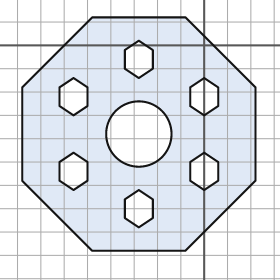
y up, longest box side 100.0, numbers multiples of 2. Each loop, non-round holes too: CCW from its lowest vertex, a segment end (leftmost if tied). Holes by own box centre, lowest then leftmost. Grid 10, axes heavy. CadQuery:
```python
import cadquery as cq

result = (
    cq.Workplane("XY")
    .moveTo(-48.0, -88.0)
    .lineTo(-8.0, -88.0)
    .lineTo(22.0, -58.0)
    .lineTo(22.0, -18.0)
    .lineTo(-8.0, 12.0)
    .lineTo(-48.0, 12.0)
    .lineTo(-78.0, -18.0)
    .lineTo(-78.0, -58.0)
    .close()
    .moveTo(-28.0, -78.0)
    .lineTo(-22.0, -74.0)
    .lineTo(-22.0, -66.0)
    .lineTo(-28.0, -62.0)
    .lineTo(-34.0, -66.0)
    .lineTo(-34.0, -74.0)
    .close()
    .moveTo(-56.0, -62.0)
    .lineTo(-50.0, -58.0)
    .lineTo(-50.0, -50.0)
    .lineTo(-56.0, -46.0)
    .lineTo(-62.0, -50.0)
    .lineTo(-62.0, -58.0)
    .close()
    .moveTo(0.0, -62.0)
    .lineTo(6.0, -58.0)
    .lineTo(6.0, -50.0)
    .lineTo(0.0, -46.0)
    .lineTo(-6.0, -50.0)
    .lineTo(-6.0, -58.0)
    .close()
    .moveTo(-28.0, -38.0)
    .circle(14.0)
    .moveTo(-56.0, -30.0)
    .lineTo(-50.0, -26.0)
    .lineTo(-50.0, -18.0)
    .lineTo(-56.0, -14.0)
    .lineTo(-62.0, -18.0)
    .lineTo(-62.0, -26.0)
    .close()
    .moveTo(0.0, -30.0)
    .lineTo(6.0, -26.0)
    .lineTo(6.0, -18.0)
    .lineTo(0.0, -14.0)
    .lineTo(-6.0, -18.0)
    .lineTo(-6.0, -26.0)
    .close()
    .moveTo(-28.0, -14.0)
    .lineTo(-22.0, -10.0)
    .lineTo(-22.0, -2.0)
    .lineTo(-28.0, 2.0)
    .lineTo(-34.0, -2.0)
    .lineTo(-34.0, -10.0)
    .close()
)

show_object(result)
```